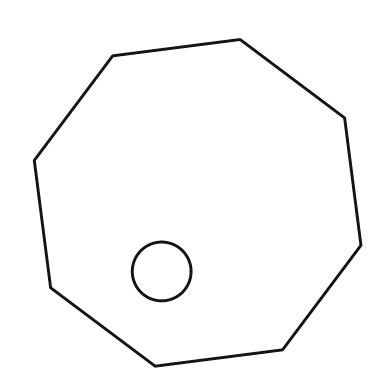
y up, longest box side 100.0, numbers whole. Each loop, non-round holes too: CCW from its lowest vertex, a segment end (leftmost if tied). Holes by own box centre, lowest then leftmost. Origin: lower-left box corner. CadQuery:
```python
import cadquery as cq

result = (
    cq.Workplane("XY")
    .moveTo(37.0, 0.0)
    .lineTo(76.0, 5.0)
    .lineTo(100.0, 37.0)
    .lineTo(95.0, 76.0)
    .lineTo(63.0, 100.0)
    .lineTo(24.0, 95.0)
    .lineTo(0.0, 63.0)
    .lineTo(5.0, 24.0)
    .close()
    .moveTo(39.0, 29.0)
    .circle(9.0)
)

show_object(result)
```